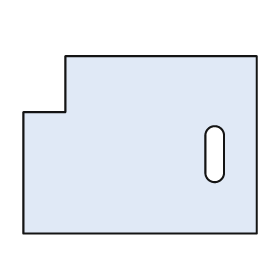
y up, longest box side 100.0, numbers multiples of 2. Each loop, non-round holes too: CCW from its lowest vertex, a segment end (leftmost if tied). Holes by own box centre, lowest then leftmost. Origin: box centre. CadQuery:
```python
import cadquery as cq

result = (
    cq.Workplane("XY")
    .moveTo(-50.0, -38.0)
    .lineTo(50.0, -38.0)
    .lineTo(50.0, 38.0)
    .lineTo(-32.0, 38.0)
    .lineTo(-32.0, 14.0)
    .lineTo(-50.0, 14.0)
    .close()
    .moveTo(28.0, -12.0)
    .threePointArc((32.0, -16.0), (36.0, -12.0))
    .lineTo(36.0, 4.0)
    .threePointArc((32.0, 8.0), (28.0, 4.0))
    .close()
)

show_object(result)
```